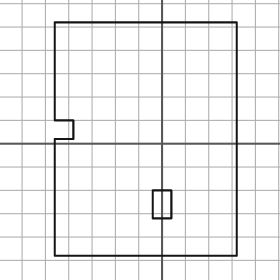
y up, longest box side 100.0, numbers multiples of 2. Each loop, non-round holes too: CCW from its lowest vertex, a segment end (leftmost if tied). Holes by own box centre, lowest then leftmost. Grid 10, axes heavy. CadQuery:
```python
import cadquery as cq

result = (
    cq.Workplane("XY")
    .moveTo(-46.0, -48.0)
    .lineTo(32.0, -48.0)
    .lineTo(32.0, 52.0)
    .lineTo(-46.0, 52.0)
    .lineTo(-46.0, 10.0)
    .lineTo(-38.0, 10.0)
    .lineTo(-38.0, 2.0)
    .lineTo(-46.0, 2.0)
    .close()
    .moveTo(-4.0, -32.0)
    .lineTo(4.0, -32.0)
    .lineTo(4.0, -20.0)
    .lineTo(-4.0, -20.0)
    .close()
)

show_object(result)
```